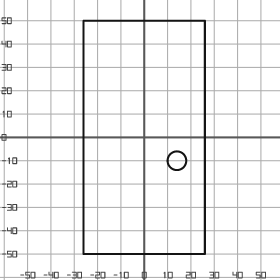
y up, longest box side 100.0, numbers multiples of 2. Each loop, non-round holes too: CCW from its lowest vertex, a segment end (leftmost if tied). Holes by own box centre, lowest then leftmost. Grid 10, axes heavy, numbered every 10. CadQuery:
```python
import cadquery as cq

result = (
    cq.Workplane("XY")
    .moveTo(-26.0, -50.0)
    .lineTo(26.0, -50.0)
    .lineTo(26.0, 50.0)
    .lineTo(-26.0, 50.0)
    .close()
    .moveTo(14.0, -10.0)
    .circle(4.0)
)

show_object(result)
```